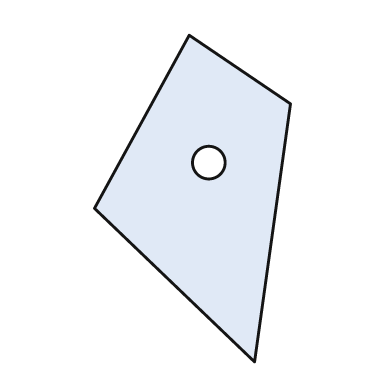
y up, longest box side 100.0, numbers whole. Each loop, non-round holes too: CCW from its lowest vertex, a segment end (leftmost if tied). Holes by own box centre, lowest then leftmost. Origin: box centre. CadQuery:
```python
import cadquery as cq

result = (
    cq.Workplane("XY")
    .moveTo(19.0, -50.0)
    .lineTo(30.0, 29.0)
    .lineTo(-1.0, 50.0)
    .lineTo(-30.0, -3.0)
    .close()
    .moveTo(5.0, 11.0)
    .circle(5.0)
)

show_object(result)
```